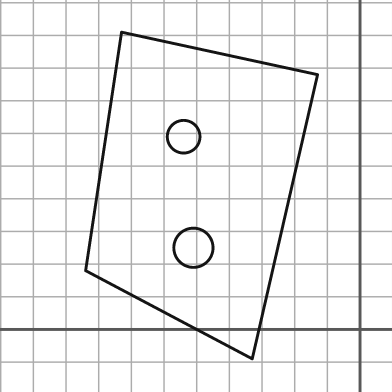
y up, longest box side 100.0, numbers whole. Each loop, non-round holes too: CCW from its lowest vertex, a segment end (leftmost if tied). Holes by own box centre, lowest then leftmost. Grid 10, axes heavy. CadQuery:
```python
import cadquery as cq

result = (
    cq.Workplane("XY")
    .moveTo(-33.0, -9.0)
    .lineTo(-13.0, 78.0)
    .lineTo(-73.0, 91.0)
    .lineTo(-84.0, 18.0)
    .close()
    .moveTo(-51.0, 25.0)
    .circle(6.0)
    .moveTo(-54.0, 59.0)
    .circle(5.0)
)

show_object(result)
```